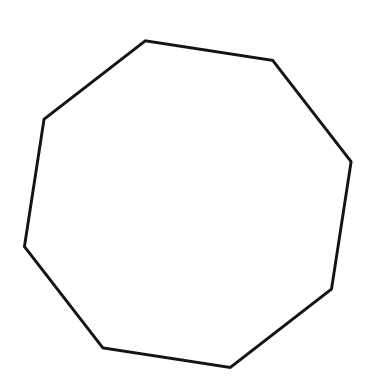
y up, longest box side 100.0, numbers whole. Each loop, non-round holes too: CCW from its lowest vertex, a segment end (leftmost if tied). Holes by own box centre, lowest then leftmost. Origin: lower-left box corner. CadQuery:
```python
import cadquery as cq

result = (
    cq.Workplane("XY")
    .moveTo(63.0, 0.0)
    .lineTo(94.0, 24.0)
    .lineTo(100.0, 63.0)
    .lineTo(76.0, 94.0)
    .lineTo(37.0, 100.0)
    .lineTo(6.0, 76.0)
    .lineTo(0.0, 37.0)
    .lineTo(24.0, 6.0)
    .close()
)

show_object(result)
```